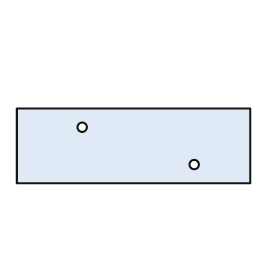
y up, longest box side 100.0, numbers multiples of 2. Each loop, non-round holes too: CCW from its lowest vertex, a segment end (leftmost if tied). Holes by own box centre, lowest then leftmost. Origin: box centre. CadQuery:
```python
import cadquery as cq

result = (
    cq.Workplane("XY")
    .moveTo(-50.0, -16.0)
    .lineTo(50.0, -16.0)
    .lineTo(50.0, 16.0)
    .lineTo(-50.0, 16.0)
    .close()
    .moveTo(26.0, -8.0)
    .circle(2.0)
    .moveTo(-22.0, 8.0)
    .circle(2.0)
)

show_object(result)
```